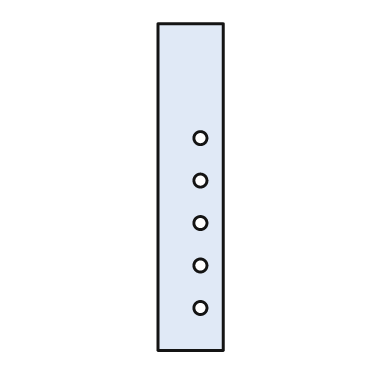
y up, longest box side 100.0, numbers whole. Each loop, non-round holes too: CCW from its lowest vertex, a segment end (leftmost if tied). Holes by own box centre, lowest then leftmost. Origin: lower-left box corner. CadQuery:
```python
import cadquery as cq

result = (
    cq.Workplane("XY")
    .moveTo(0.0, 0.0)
    .lineTo(20.0, 0.0)
    .lineTo(20.0, 100.0)
    .lineTo(0.0, 100.0)
    .close()
    .moveTo(13.0, 13.0)
    .circle(2.0)
    .moveTo(13.0, 26.0)
    .circle(2.0)
    .moveTo(13.0, 39.0)
    .circle(2.0)
    .moveTo(13.0, 52.0)
    .circle(2.0)
    .moveTo(13.0, 65.0)
    .circle(2.0)
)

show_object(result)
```